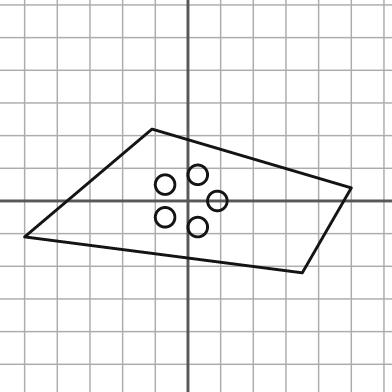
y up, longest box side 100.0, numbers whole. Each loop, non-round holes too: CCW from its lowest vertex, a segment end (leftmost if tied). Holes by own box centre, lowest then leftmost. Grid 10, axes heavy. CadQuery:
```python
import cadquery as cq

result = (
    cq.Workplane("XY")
    .moveTo(35.0, -22.0)
    .lineTo(50.0, 4.0)
    .lineTo(-11.0, 22.0)
    .lineTo(-50.0, -11.0)
    .close()
    .moveTo(3.0, -8.0)
    .circle(3.0)
    .moveTo(-7.0, -5.0)
    .circle(3.0)
    .moveTo(9.0, 0.0)
    .circle(3.0)
    .moveTo(-7.0, 5.0)
    .circle(3.0)
    .moveTo(3.0, 8.0)
    .circle(3.0)
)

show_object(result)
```